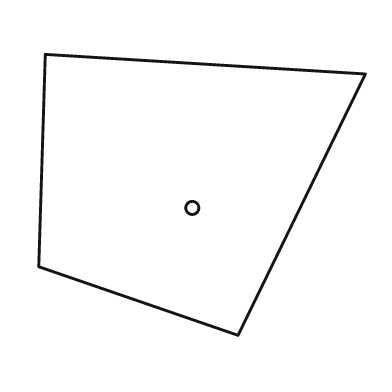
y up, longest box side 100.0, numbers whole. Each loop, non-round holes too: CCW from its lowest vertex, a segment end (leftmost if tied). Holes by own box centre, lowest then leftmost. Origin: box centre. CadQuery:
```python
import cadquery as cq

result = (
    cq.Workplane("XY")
    .moveTo(11.0, -43.0)
    .lineTo(50.0, 37.0)
    .lineTo(-48.0, 43.0)
    .lineTo(-50.0, -22.0)
    .close()
    .moveTo(-3.0, -4.0)
    .circle(2.0)
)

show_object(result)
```